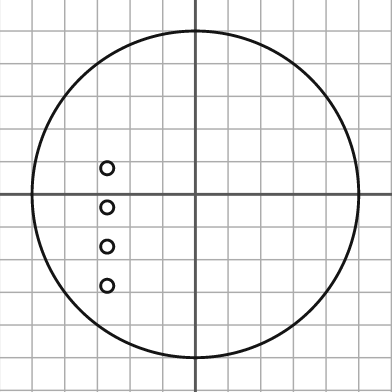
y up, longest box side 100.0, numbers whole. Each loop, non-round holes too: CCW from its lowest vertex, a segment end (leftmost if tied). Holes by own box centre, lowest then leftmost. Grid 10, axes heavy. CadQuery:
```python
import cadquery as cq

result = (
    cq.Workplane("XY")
    .moveTo(0.0, 0.0)
    .circle(50.0)
    .moveTo(-27.0, -28.0)
    .circle(2.0)
    .moveTo(-27.0, -16.0)
    .circle(2.0)
    .moveTo(-27.0, -4.0)
    .circle(2.0)
    .moveTo(-27.0, 8.0)
    .circle(2.0)
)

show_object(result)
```